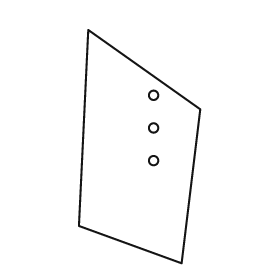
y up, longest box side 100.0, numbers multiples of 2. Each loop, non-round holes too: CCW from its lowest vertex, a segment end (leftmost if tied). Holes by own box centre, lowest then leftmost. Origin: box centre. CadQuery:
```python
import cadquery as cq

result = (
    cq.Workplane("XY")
    .moveTo(18.0, -50.0)
    .lineTo(26.0, 16.0)
    .lineTo(-22.0, 50.0)
    .lineTo(-26.0, -34.0)
    .close()
    .moveTo(6.0, -6.0)
    .circle(2.0)
    .moveTo(6.0, 8.0)
    .circle(2.0)
    .moveTo(6.0, 22.0)
    .circle(2.0)
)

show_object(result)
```